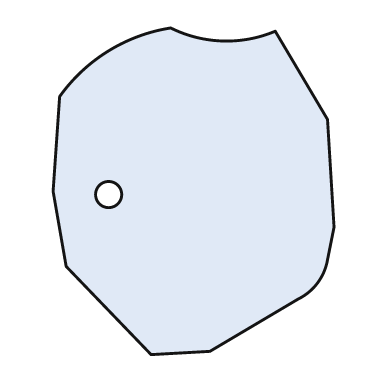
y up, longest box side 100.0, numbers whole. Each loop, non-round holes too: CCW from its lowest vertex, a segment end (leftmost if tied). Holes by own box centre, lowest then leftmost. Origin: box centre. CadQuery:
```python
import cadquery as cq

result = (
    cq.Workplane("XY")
    .moveTo(-13.0, -50.0)
    .lineTo(5.0, -49.0)
    .lineTo(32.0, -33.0)
    .threePointArc((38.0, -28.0), (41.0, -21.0))
    .lineTo(43.0, -11.0)
    .lineTo(41.0, 22.0)
    .lineTo(25.0, 49.0)
    .threePointArc((9.0, 46.0), (-7.0, 50.0))
    .threePointArc((-26.0, 43.0), (-41.0, 29.0))
    .lineTo(-43.0, 0.0)
    .lineTo(-39.0, -23.0)
    .close()
    .moveTo(-26.0, -1.0)
    .circle(4.0)
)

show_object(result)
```